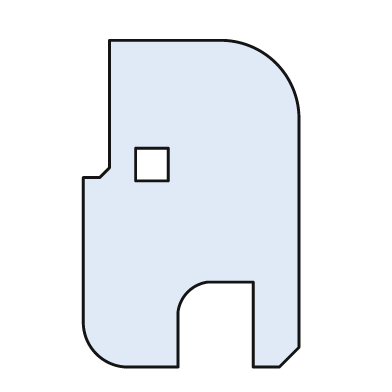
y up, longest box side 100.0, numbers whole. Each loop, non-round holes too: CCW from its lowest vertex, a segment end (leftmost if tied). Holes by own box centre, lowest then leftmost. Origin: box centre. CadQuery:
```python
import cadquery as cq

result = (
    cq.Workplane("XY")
    .moveTo(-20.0, -50.0)
    .lineTo(-4.0, -50.0)
    .lineTo(-4.0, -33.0)
    .threePointArc((-1.0, -27.0), (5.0, -24.0))
    .lineTo(19.0, -24.0)
    .lineTo(19.0, -50.0)
    .lineTo(27.0, -50.0)
    .lineTo(33.0, -44.0)
    .lineTo(33.0, 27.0)
    .threePointArc((26.0, 43.0), (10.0, 50.0))
    .lineTo(-25.0, 50.0)
    .lineTo(-25.0, 11.0)
    .lineTo(-28.0, 8.0)
    .lineTo(-33.0, 8.0)
    .lineTo(-33.0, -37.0)
    .threePointArc((-29.0, -46.0), (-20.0, -50.0))
    .close()
    .moveTo(-17.0, 7.0)
    .lineTo(-7.0, 7.0)
    .lineTo(-7.0, 17.0)
    .lineTo(-17.0, 17.0)
    .close()
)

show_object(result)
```